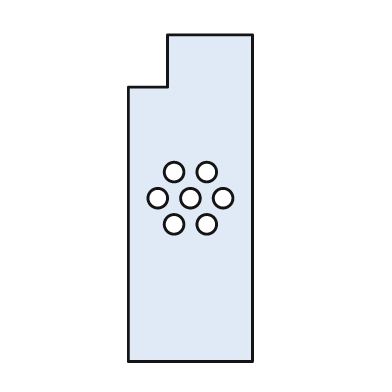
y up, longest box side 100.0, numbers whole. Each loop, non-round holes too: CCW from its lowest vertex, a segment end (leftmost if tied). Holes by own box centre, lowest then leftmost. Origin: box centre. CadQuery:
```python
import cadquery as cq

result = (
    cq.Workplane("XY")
    .moveTo(-19.0, -50.0)
    .lineTo(19.0, -50.0)
    .lineTo(19.0, 50.0)
    .lineTo(-7.0, 50.0)
    .lineTo(-7.0, 34.0)
    .lineTo(-19.0, 34.0)
    .close()
    .moveTo(-5.0, -8.0)
    .circle(3.0)
    .moveTo(5.0, -8.0)
    .circle(3.0)
    .moveTo(-10.0, 0.0)
    .circle(3.0)
    .moveTo(0.0, 0.0)
    .circle(3.0)
    .moveTo(10.0, 0.0)
    .circle(3.0)
    .moveTo(-5.0, 8.0)
    .circle(3.0)
    .moveTo(5.0, 8.0)
    .circle(3.0)
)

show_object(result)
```